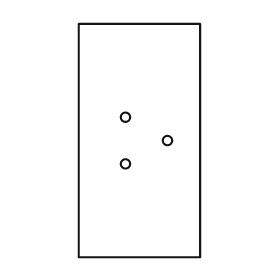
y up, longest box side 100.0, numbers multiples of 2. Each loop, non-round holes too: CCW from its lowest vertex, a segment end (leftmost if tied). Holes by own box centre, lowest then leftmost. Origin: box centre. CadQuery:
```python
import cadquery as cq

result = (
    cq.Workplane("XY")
    .moveTo(-26.0, -50.0)
    .lineTo(26.0, -50.0)
    .lineTo(26.0, 50.0)
    .lineTo(-26.0, 50.0)
    .close()
    .moveTo(-6.0, -10.0)
    .circle(2.0)
    .moveTo(12.0, 0.0)
    .circle(2.0)
    .moveTo(-6.0, 10.0)
    .circle(2.0)
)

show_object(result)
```